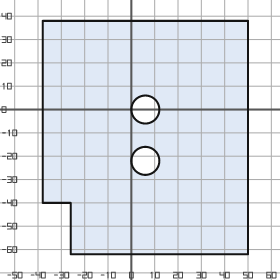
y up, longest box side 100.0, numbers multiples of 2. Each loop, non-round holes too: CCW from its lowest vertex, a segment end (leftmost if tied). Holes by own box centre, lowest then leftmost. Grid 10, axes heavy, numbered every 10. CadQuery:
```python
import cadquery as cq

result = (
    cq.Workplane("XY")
    .moveTo(-26.0, -62.0)
    .lineTo(50.0, -62.0)
    .lineTo(50.0, 38.0)
    .lineTo(-38.0, 38.0)
    .lineTo(-38.0, -40.0)
    .lineTo(-26.0, -40.0)
    .close()
    .moveTo(6.0, -22.0)
    .circle(6.0)
    .moveTo(6.0, 0.0)
    .circle(6.0)
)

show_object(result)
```